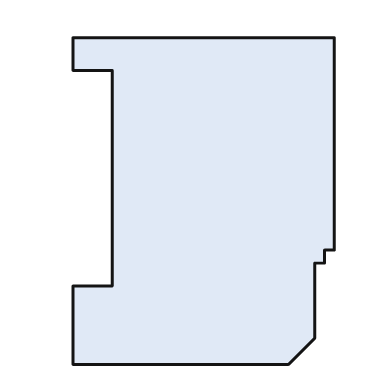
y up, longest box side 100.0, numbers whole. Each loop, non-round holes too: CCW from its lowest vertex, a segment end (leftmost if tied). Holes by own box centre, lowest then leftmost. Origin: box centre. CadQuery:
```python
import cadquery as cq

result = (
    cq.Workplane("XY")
    .moveTo(-40.0, -50.0)
    .lineTo(26.0, -50.0)
    .lineTo(34.0, -42.0)
    .lineTo(34.0, -19.0)
    .lineTo(37.0, -19.0)
    .lineTo(37.0, -15.0)
    .lineTo(40.0, -15.0)
    .lineTo(40.0, 50.0)
    .lineTo(-40.0, 50.0)
    .lineTo(-40.0, 40.0)
    .lineTo(-28.0, 40.0)
    .lineTo(-28.0, -26.0)
    .lineTo(-40.0, -26.0)
    .close()
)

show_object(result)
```